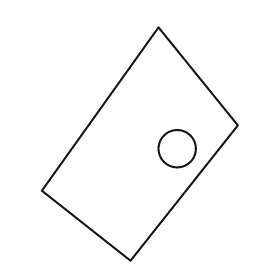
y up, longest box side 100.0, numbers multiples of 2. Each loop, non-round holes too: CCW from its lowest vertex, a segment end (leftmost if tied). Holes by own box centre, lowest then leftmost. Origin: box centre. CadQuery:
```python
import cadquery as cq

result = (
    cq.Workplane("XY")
    .moveTo(-4.0, -50.0)
    .lineTo(42.0, 8.0)
    .lineTo(8.0, 50.0)
    .lineTo(-42.0, -20.0)
    .close()
    .moveTo(16.0, -2.0)
    .circle(8.0)
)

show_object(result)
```